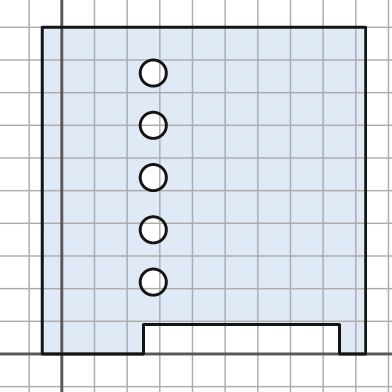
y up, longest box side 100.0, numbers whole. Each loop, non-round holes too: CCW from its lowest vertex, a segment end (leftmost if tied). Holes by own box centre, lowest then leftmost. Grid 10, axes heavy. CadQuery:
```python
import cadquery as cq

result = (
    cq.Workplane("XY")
    .moveTo(-6.0, 0.0)
    .lineTo(25.0, 0.0)
    .lineTo(25.0, 9.0)
    .lineTo(85.0, 9.0)
    .lineTo(85.0, 0.0)
    .lineTo(93.0, 0.0)
    .lineTo(93.0, 100.0)
    .lineTo(-6.0, 100.0)
    .close()
    .moveTo(28.0, 22.0)
    .circle(4.0)
    .moveTo(28.0, 38.0)
    .circle(4.0)
    .moveTo(28.0, 54.0)
    .circle(4.0)
    .moveTo(28.0, 70.0)
    .circle(4.0)
    .moveTo(28.0, 86.0)
    .circle(4.0)
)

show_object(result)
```